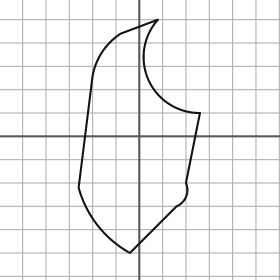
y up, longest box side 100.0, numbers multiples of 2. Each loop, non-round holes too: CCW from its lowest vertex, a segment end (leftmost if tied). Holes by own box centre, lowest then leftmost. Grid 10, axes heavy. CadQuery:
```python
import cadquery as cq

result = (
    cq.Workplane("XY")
    .moveTo(-4.0, -50.0)
    .lineTo(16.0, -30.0)
    .threePointArc((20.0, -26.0), (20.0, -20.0))
    .lineTo(26.0, 10.0)
    .threePointArc((4.0, 24.0), (8.0, 50.0))
    .lineTo(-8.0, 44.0)
    .threePointArc((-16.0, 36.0), (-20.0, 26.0))
    .lineTo(-26.0, -22.0)
    .threePointArc((-18.0, -38.0), (-4.0, -50.0))
    .close()
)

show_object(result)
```